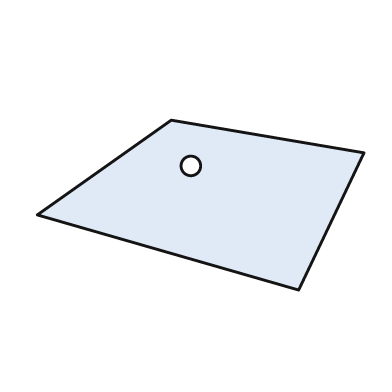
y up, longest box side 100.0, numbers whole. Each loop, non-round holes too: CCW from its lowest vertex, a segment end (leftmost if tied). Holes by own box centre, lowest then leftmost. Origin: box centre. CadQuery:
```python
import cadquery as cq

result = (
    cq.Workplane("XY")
    .moveTo(30.0, -26.0)
    .lineTo(50.0, 16.0)
    .lineTo(-9.0, 26.0)
    .lineTo(-50.0, -3.0)
    .close()
    .moveTo(-3.0, 12.0)
    .circle(3.0)
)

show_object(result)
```